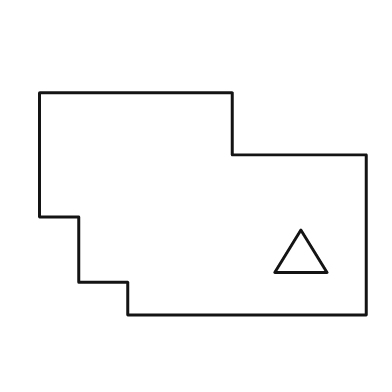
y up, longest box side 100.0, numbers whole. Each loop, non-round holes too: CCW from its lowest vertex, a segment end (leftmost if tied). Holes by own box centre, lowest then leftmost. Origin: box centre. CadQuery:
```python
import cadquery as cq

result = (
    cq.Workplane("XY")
    .moveTo(-23.0, -34.0)
    .lineTo(50.0, -34.0)
    .lineTo(50.0, 15.0)
    .lineTo(9.0, 15.0)
    .lineTo(9.0, 34.0)
    .lineTo(-50.0, 34.0)
    .lineTo(-50.0, -4.0)
    .lineTo(-38.0, -4.0)
    .lineTo(-38.0, -24.0)
    .lineTo(-23.0, -24.0)
    .close()
    .moveTo(22.0, -21.0)
    .lineTo(38.0, -21.0)
    .lineTo(30.0, -8.0)
    .close()
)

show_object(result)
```